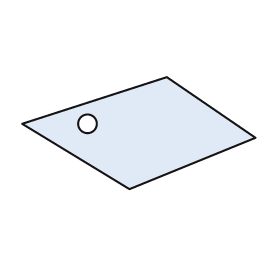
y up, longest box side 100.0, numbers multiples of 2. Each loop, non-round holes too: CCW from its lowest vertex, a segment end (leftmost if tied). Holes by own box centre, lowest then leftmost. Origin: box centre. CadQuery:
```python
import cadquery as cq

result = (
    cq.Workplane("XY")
    .moveTo(-4.0, -24.0)
    .lineTo(50.0, -2.0)
    .lineTo(12.0, 24.0)
    .lineTo(-50.0, 4.0)
    .close()
    .moveTo(-22.0, 4.0)
    .circle(4.0)
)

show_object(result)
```